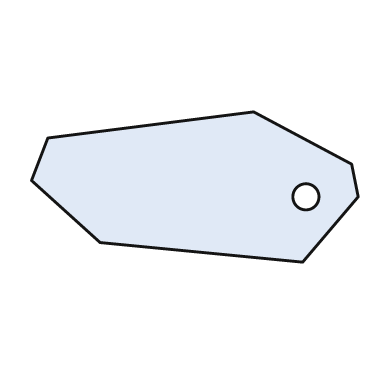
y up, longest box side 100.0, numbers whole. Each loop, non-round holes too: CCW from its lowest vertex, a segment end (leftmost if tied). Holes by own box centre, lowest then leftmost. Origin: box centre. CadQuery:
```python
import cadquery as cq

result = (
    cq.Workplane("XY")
    .moveTo(33.0, -23.0)
    .lineTo(50.0, -3.0)
    .lineTo(48.0, 7.0)
    .lineTo(18.0, 23.0)
    .lineTo(-45.0, 15.0)
    .lineTo(-50.0, 2.0)
    .lineTo(-29.0, -17.0)
    .close()
    .moveTo(34.0, -3.0)
    .circle(4.0)
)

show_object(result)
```